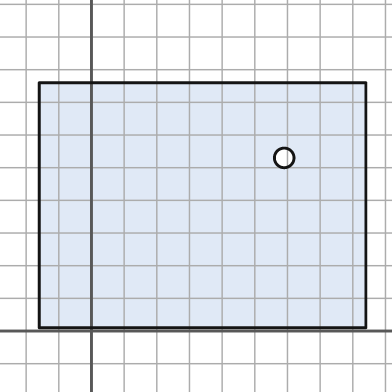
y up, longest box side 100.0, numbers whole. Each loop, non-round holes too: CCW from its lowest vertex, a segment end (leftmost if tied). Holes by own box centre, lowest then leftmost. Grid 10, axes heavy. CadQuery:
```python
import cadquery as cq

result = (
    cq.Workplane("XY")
    .moveTo(-16.0, 1.0)
    .lineTo(84.0, 1.0)
    .lineTo(84.0, 76.0)
    .lineTo(-16.0, 76.0)
    .close()
    .moveTo(59.0, 53.0)
    .circle(3.0)
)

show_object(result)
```